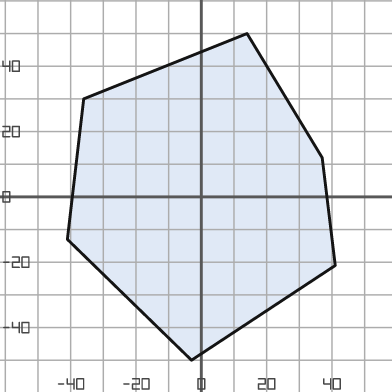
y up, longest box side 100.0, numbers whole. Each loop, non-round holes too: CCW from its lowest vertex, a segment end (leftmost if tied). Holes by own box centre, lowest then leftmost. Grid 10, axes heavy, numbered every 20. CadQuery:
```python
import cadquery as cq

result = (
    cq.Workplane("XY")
    .moveTo(-3.0, -50.0)
    .lineTo(41.0, -21.0)
    .lineTo(37.0, 12.0)
    .lineTo(14.0, 50.0)
    .lineTo(-36.0, 30.0)
    .lineTo(-41.0, -13.0)
    .close()
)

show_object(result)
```